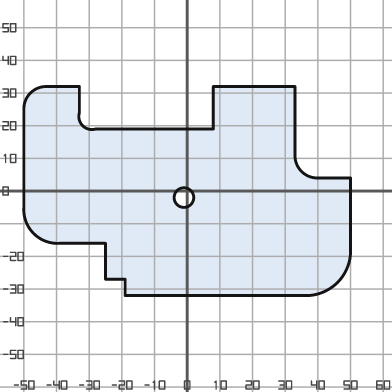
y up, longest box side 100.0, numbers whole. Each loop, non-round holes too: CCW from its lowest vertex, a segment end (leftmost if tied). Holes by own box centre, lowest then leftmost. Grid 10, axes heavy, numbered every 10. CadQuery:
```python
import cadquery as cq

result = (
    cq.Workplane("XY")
    .moveTo(-19.0, -32.0)
    .lineTo(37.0, -32.0)
    .threePointArc((46.0, -28.0), (50.0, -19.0))
    .lineTo(50.0, 4.0)
    .lineTo(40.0, 4.0)
    .threePointArc((35.0, 6.0), (33.0, 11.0))
    .lineTo(33.0, 32.0)
    .lineTo(8.0, 32.0)
    .lineTo(8.0, 19.0)
    .lineTo(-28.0, 19.0)
    .threePointArc((-32.0, 20.0), (-33.0, 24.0))
    .lineTo(-33.0, 32.0)
    .lineTo(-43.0, 32.0)
    .threePointArc((-48.0, 30.0), (-50.0, 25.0))
    .lineTo(-50.0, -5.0)
    .threePointArc((-47.0, -13.0), (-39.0, -16.0))
    .lineTo(-25.0, -16.0)
    .lineTo(-25.0, -27.0)
    .lineTo(-19.0, -27.0)
    .close()
    .moveTo(-1.0, -2.0)
    .circle(3.0)
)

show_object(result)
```